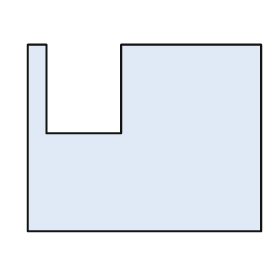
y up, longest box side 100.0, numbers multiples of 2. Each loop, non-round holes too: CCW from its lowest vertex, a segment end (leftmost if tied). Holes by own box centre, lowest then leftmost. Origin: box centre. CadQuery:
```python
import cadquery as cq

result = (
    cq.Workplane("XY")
    .moveTo(-50.0, -40.0)
    .lineTo(50.0, -40.0)
    .lineTo(50.0, 40.0)
    .lineTo(-10.0, 40.0)
    .lineTo(-10.0, 2.0)
    .lineTo(-42.0, 2.0)
    .lineTo(-42.0, 40.0)
    .lineTo(-50.0, 40.0)
    .close()
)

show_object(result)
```